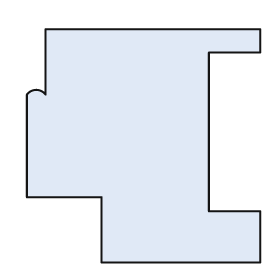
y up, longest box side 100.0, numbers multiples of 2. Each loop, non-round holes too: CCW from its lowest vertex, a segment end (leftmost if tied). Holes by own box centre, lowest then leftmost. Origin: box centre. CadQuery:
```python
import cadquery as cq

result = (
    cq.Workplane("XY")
    .moveTo(-18.0, -50.0)
    .lineTo(50.0, -50.0)
    .lineTo(50.0, -28.0)
    .lineTo(28.0, -28.0)
    .lineTo(28.0, 40.0)
    .lineTo(50.0, 40.0)
    .lineTo(50.0, 50.0)
    .lineTo(-42.0, 50.0)
    .lineTo(-42.0, 22.0)
    .threePointArc((-46.0, 24.0), (-50.0, 22.0))
    .lineTo(-50.0, -22.0)
    .lineTo(-18.0, -22.0)
    .close()
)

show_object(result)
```